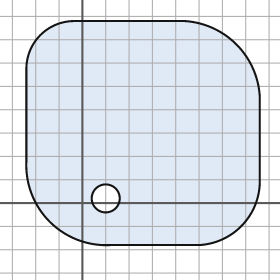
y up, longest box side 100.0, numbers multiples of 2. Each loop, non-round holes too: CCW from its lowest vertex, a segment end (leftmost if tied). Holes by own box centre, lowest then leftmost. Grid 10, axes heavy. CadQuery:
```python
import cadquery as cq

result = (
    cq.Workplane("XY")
    .moveTo(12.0, -18.0)
    .lineTo(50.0, -18.0)
    .threePointArc((68.0, -10.0), (76.0, 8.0))
    .lineTo(76.0, 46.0)
    .threePointArc((66.0, 68.0), (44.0, 78.0))
    .lineTo(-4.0, 78.0)
    .threePointArc((-18.0, 72.0), (-24.0, 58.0))
    .lineTo(-24.0, 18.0)
    .threePointArc((-14.0, -8.0), (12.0, -18.0))
    .close()
    .moveTo(10.0, 2.0)
    .circle(6.0)
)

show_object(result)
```